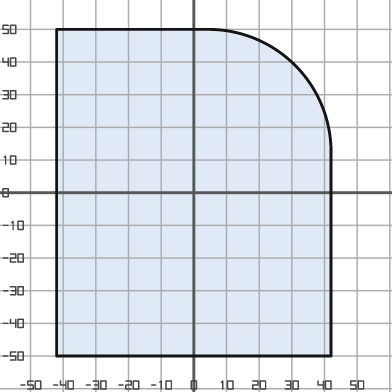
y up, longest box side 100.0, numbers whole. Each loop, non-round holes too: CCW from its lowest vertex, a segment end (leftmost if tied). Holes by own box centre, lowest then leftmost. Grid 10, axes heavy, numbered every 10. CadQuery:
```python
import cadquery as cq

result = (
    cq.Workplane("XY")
    .moveTo(-42.0, -50.0)
    .lineTo(42.0, -50.0)
    .lineTo(42.0, 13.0)
    .threePointArc((31.0, 39.0), (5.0, 50.0))
    .lineTo(-42.0, 50.0)
    .close()
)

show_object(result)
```